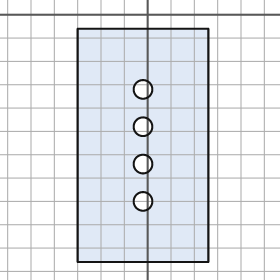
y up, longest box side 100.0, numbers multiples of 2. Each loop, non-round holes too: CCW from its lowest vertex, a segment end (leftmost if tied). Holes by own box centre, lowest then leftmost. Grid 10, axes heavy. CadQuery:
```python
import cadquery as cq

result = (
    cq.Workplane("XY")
    .moveTo(-30.0, -106.0)
    .lineTo(26.0, -106.0)
    .lineTo(26.0, -6.0)
    .lineTo(-30.0, -6.0)
    .close()
    .moveTo(-2.0, -80.0)
    .circle(4.0)
    .moveTo(-2.0, -64.0)
    .circle(4.0)
    .moveTo(-2.0, -48.0)
    .circle(4.0)
    .moveTo(-2.0, -32.0)
    .circle(4.0)
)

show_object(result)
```